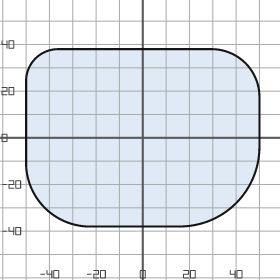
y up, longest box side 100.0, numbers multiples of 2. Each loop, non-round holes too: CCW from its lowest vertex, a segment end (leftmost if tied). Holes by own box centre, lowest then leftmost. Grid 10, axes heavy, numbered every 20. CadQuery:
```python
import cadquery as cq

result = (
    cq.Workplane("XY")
    .moveTo(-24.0, -38.0)
    .lineTo(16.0, -38.0)
    .threePointArc((40.0, -28.0), (50.0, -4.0))
    .lineTo(50.0, 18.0)
    .threePointArc((44.0, 32.0), (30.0, 38.0))
    .lineTo(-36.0, 38.0)
    .threePointArc((-46.0, 34.0), (-50.0, 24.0))
    .lineTo(-50.0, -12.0)
    .threePointArc((-42.0, -30.0), (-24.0, -38.0))
    .close()
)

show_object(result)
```